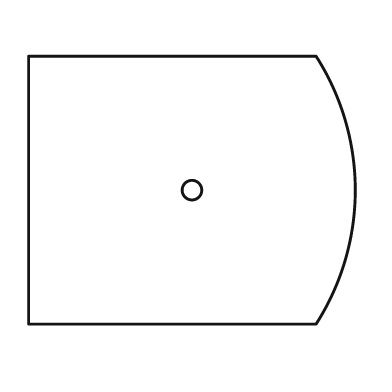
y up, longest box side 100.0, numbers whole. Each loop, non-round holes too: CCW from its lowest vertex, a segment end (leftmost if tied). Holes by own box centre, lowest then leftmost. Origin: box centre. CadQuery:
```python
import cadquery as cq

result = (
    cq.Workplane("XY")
    .moveTo(-50.0, -41.0)
    .lineTo(38.0, -41.0)
    .threePointArc((50.0, 0.0), (38.0, 41.0))
    .lineTo(-50.0, 41.0)
    .close()
    .moveTo(0.0, 0.0)
    .circle(3.0)
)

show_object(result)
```